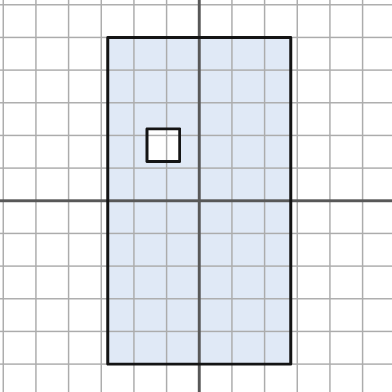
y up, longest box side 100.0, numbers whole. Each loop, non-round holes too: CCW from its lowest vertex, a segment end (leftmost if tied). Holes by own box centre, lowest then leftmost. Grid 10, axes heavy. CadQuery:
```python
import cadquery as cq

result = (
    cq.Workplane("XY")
    .moveTo(-28.0, -50.0)
    .lineTo(28.0, -50.0)
    .lineTo(28.0, 50.0)
    .lineTo(-28.0, 50.0)
    .close()
    .moveTo(-16.0, 12.0)
    .lineTo(-6.0, 12.0)
    .lineTo(-6.0, 22.0)
    .lineTo(-16.0, 22.0)
    .close()
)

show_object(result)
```